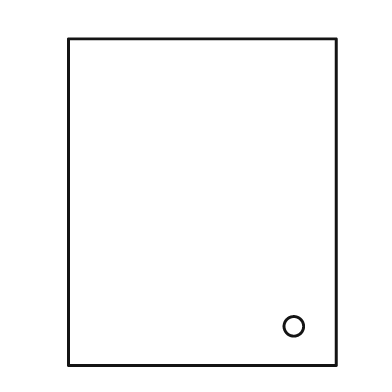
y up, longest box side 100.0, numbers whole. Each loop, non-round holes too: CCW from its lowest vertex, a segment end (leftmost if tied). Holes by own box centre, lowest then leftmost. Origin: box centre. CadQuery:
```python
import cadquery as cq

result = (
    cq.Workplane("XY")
    .moveTo(-41.0, -50.0)
    .lineTo(41.0, -50.0)
    .lineTo(41.0, 50.0)
    .lineTo(-41.0, 50.0)
    .close()
    .moveTo(28.0, -38.0)
    .circle(3.0)
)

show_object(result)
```